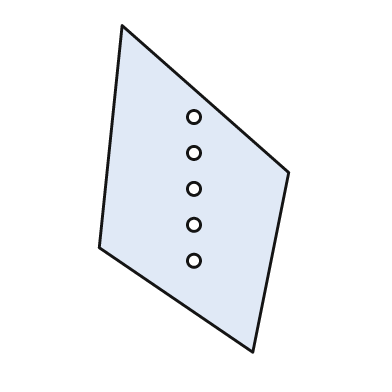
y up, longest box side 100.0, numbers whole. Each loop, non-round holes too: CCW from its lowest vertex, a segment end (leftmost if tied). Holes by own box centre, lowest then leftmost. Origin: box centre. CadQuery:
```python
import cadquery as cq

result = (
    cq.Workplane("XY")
    .moveTo(18.0, -50.0)
    .lineTo(29.0, 5.0)
    .lineTo(-22.0, 50.0)
    .lineTo(-29.0, -18.0)
    .close()
    .moveTo(0.0, -22.0)
    .circle(2.0)
    .moveTo(0.0, -11.0)
    .circle(2.0)
    .moveTo(0.0, 0.0)
    .circle(2.0)
    .moveTo(0.0, 11.0)
    .circle(2.0)
    .moveTo(0.0, 22.0)
    .circle(2.0)
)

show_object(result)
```